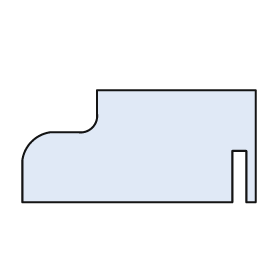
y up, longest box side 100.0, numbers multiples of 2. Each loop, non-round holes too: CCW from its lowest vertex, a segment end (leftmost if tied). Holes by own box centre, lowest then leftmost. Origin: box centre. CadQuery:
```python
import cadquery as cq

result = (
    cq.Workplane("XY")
    .moveTo(-50.0, -24.0)
    .lineTo(40.0, -24.0)
    .lineTo(40.0, -2.0)
    .lineTo(46.0, -2.0)
    .lineTo(46.0, -24.0)
    .lineTo(50.0, -24.0)
    .lineTo(50.0, 24.0)
    .lineTo(-18.0, 24.0)
    .lineTo(-18.0, 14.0)
    .threePointArc((-20.0, 8.0), (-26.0, 6.0))
    .lineTo(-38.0, 6.0)
    .threePointArc((-46.0, 2.0), (-50.0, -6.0))
    .close()
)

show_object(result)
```